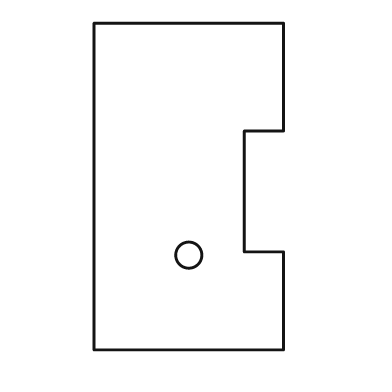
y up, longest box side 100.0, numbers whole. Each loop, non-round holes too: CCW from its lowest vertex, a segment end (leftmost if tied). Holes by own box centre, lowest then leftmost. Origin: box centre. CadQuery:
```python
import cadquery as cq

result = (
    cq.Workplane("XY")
    .moveTo(-29.0, -50.0)
    .lineTo(29.0, -50.0)
    .lineTo(29.0, -20.0)
    .lineTo(17.0, -20.0)
    .lineTo(17.0, 17.0)
    .lineTo(29.0, 17.0)
    .lineTo(29.0, 50.0)
    .lineTo(-29.0, 50.0)
    .close()
    .moveTo(0.0, -21.0)
    .circle(4.0)
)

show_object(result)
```